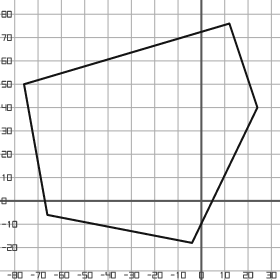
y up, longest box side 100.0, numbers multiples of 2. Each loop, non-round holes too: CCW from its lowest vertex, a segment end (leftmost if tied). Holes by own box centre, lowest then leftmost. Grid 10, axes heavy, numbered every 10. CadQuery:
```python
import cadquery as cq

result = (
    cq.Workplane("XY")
    .moveTo(-4.0, -18.0)
    .lineTo(24.0, 40.0)
    .lineTo(12.0, 76.0)
    .lineTo(-76.0, 50.0)
    .lineTo(-66.0, -6.0)
    .close()
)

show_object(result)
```